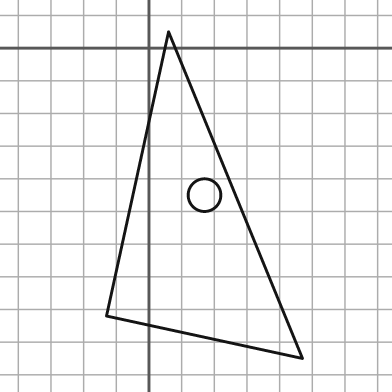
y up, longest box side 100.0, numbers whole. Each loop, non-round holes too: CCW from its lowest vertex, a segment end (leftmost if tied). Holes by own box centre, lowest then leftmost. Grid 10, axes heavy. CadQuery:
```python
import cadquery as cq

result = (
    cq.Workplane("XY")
    .moveTo(47.0, -95.0)
    .lineTo(6.0, 5.0)
    .lineTo(-13.0, -82.0)
    .close()
    .moveTo(17.0, -45.0)
    .circle(5.0)
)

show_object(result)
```